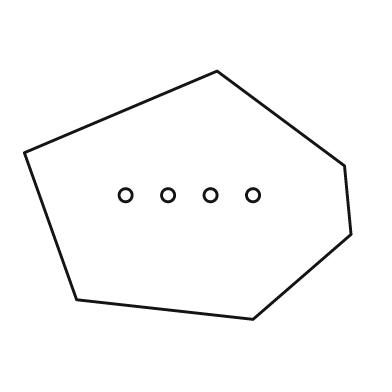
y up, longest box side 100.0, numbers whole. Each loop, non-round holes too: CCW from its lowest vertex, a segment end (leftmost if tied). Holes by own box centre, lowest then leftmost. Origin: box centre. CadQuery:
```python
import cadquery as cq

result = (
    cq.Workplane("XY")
    .moveTo(20.0, -38.0)
    .lineTo(50.0, -12.0)
    .lineTo(48.0, 9.0)
    .lineTo(9.0, 38.0)
    .lineTo(-50.0, 13.0)
    .lineTo(-34.0, -32.0)
    .close()
    .moveTo(-19.0, 0.0)
    .circle(2.0)
    .moveTo(-6.0, 0.0)
    .circle(2.0)
    .moveTo(7.0, 0.0)
    .circle(2.0)
    .moveTo(20.0, 0.0)
    .circle(2.0)
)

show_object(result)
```